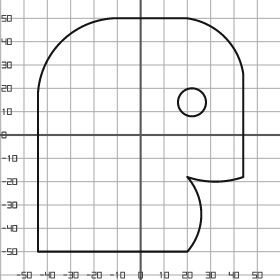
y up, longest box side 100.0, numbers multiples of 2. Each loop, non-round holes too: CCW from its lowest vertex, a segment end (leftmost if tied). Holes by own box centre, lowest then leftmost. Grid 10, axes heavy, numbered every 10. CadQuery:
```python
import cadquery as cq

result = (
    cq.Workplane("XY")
    .moveTo(-44.0, -50.0)
    .lineTo(20.0, -50.0)
    .threePointArc((26.0, -34.0), (20.0, -18.0))
    .threePointArc((32.0, -20.0), (44.0, -18.0))
    .lineTo(44.0, 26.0)
    .threePointArc((36.0, 42.0), (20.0, 50.0))
    .lineTo(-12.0, 50.0)
    .threePointArc((-34.0, 40.0), (-44.0, 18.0))
    .close()
    .moveTo(22.0, 14.0)
    .circle(6.0)
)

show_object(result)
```